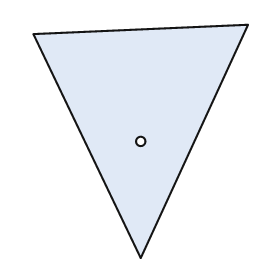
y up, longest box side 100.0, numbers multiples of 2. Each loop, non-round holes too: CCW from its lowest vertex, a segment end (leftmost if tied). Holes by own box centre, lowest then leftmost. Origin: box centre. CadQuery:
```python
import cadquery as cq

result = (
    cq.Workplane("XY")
    .moveTo(0.0, -50.0)
    .lineTo(46.0, 50.0)
    .lineTo(-46.0, 46.0)
    .close()
    .moveTo(0.0, 0.0)
    .circle(2.0)
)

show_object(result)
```